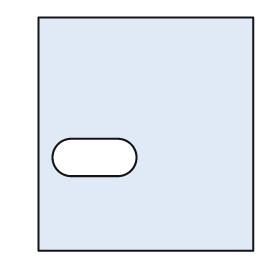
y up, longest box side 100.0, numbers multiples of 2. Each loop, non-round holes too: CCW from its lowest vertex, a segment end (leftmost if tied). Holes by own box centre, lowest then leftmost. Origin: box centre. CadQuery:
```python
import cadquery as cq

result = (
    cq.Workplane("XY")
    .moveTo(-46.0, -50.0)
    .lineTo(46.0, -50.0)
    .lineTo(46.0, 50.0)
    .lineTo(-46.0, 50.0)
    .close()
    .moveTo(-32.0, -18.0)
    .lineTo(-12.0, -18.0)
    .threePointArc((-4.0, -10.0), (-12.0, -2.0))
    .lineTo(-32.0, -2.0)
    .threePointArc((-40.0, -10.0), (-32.0, -18.0))
    .close()
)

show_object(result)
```